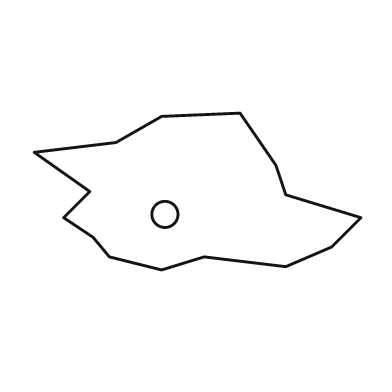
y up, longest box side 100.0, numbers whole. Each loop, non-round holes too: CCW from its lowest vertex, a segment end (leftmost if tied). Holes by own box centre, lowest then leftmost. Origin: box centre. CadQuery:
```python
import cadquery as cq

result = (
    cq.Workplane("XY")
    .moveTo(-11.0, -24.0)
    .lineTo(2.0, -20.0)
    .lineTo(27.0, -23.0)
    .lineTo(41.0, -17.0)
    .lineTo(50.0, -8.0)
    .lineTo(27.0, -1.0)
    .lineTo(24.0, 8.0)
    .lineTo(13.0, 24.0)
    .lineTo(-11.0, 23.0)
    .lineTo(-25.0, 15.0)
    .lineTo(-50.0, 12.0)
    .lineTo(-33.0, 0.0)
    .lineTo(-41.0, -8.0)
    .lineTo(-32.0, -14.0)
    .lineTo(-27.0, -20.0)
    .close()
    .moveTo(-10.0, -7.0)
    .circle(4.0)
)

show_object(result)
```